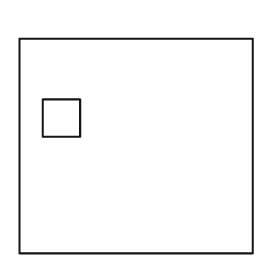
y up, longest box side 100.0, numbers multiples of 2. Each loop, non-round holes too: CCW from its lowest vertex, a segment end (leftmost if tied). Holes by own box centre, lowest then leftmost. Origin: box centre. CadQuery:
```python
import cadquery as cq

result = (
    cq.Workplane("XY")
    .moveTo(-50.0, -46.0)
    .lineTo(50.0, -46.0)
    .lineTo(50.0, 46.0)
    .lineTo(-50.0, 46.0)
    .close()
    .moveTo(-40.0, 4.0)
    .lineTo(-24.0, 4.0)
    .lineTo(-24.0, 20.0)
    .lineTo(-40.0, 20.0)
    .close()
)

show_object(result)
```